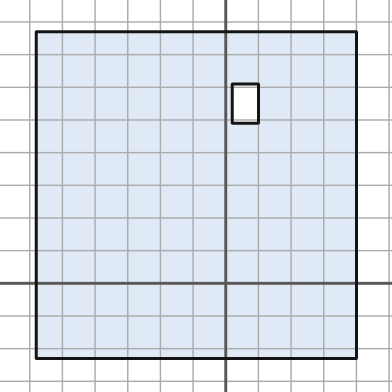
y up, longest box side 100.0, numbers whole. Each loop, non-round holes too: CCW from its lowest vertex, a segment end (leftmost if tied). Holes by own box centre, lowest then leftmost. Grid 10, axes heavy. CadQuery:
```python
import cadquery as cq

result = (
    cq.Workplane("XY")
    .moveTo(-58.0, -23.0)
    .lineTo(40.0, -23.0)
    .lineTo(40.0, 77.0)
    .lineTo(-58.0, 77.0)
    .close()
    .moveTo(2.0, 49.0)
    .lineTo(10.0, 49.0)
    .lineTo(10.0, 61.0)
    .lineTo(2.0, 61.0)
    .close()
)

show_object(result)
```